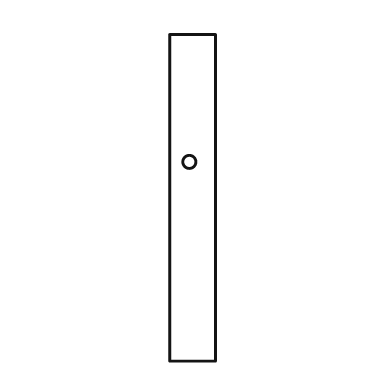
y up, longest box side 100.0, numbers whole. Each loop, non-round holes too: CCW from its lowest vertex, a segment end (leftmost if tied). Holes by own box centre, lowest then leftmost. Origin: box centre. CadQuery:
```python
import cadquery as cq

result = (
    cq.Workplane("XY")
    .moveTo(-7.0, -50.0)
    .lineTo(7.0, -50.0)
    .lineTo(7.0, 50.0)
    .lineTo(-7.0, 50.0)
    .close()
    .moveTo(-1.0, 11.0)
    .circle(2.0)
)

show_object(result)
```